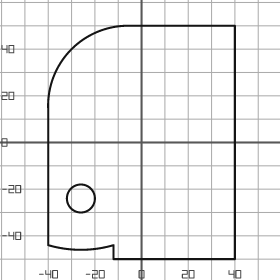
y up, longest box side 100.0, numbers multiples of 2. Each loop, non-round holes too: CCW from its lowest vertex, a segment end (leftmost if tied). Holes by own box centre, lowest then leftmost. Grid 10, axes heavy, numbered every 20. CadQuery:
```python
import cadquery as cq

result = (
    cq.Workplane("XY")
    .moveTo(-12.0, -50.0)
    .lineTo(40.0, -50.0)
    .lineTo(40.0, 50.0)
    .lineTo(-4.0, 50.0)
    .threePointArc((-30.0, 40.0), (-40.0, 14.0))
    .lineTo(-40.0, -44.0)
    .threePointArc((-26.0, -46.0), (-12.0, -44.0))
    .close()
    .moveTo(-26.0, -24.0)
    .circle(6.0)
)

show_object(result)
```